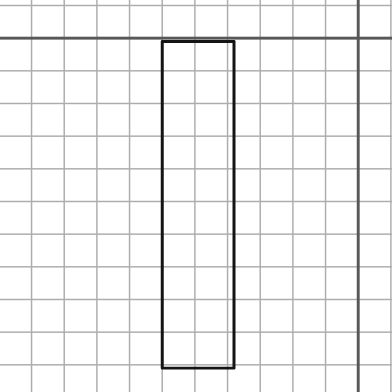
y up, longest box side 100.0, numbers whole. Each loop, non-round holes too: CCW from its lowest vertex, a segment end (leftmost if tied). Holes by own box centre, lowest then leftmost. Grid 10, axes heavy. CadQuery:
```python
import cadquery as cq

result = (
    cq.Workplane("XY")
    .moveTo(-60.0, -101.0)
    .lineTo(-38.0, -101.0)
    .lineTo(-38.0, -1.0)
    .lineTo(-60.0, -1.0)
    .close()
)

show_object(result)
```